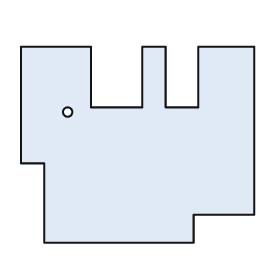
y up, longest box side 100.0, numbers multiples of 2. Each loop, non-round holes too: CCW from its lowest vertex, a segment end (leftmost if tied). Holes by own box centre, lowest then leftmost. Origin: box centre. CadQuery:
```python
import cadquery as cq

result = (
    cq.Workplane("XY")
    .moveTo(-40.0, -42.0)
    .lineTo(24.0, -42.0)
    .lineTo(24.0, -30.0)
    .lineTo(50.0, -30.0)
    .lineTo(50.0, 42.0)
    .lineTo(26.0, 42.0)
    .lineTo(26.0, 16.0)
    .lineTo(12.0, 16.0)
    .lineTo(12.0, 42.0)
    .lineTo(2.0, 42.0)
    .lineTo(2.0, 16.0)
    .lineTo(-20.0, 16.0)
    .lineTo(-20.0, 42.0)
    .lineTo(-50.0, 42.0)
    .lineTo(-50.0, -8.0)
    .lineTo(-40.0, -8.0)
    .close()
    .moveTo(-30.0, 14.0)
    .circle(2.0)
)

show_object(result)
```